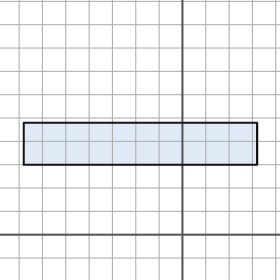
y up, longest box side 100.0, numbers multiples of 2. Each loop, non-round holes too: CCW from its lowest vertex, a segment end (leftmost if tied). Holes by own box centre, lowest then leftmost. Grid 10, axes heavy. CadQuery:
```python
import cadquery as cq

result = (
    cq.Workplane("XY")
    .moveTo(-68.0, 30.0)
    .lineTo(32.0, 30.0)
    .lineTo(32.0, 48.0)
    .lineTo(-68.0, 48.0)
    .close()
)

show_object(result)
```